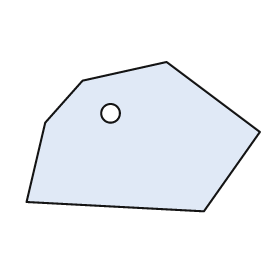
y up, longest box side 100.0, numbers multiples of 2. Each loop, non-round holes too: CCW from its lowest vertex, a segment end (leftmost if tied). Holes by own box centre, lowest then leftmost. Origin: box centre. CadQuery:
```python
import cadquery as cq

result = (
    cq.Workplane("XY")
    .moveTo(26.0, -32.0)
    .lineTo(50.0, 2.0)
    .lineTo(10.0, 32.0)
    .lineTo(-26.0, 24.0)
    .lineTo(-42.0, 6.0)
    .lineTo(-50.0, -28.0)
    .close()
    .moveTo(-14.0, 10.0)
    .circle(4.0)
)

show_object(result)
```